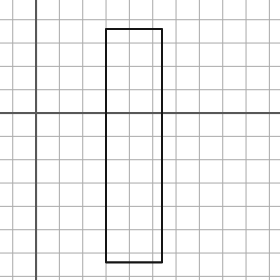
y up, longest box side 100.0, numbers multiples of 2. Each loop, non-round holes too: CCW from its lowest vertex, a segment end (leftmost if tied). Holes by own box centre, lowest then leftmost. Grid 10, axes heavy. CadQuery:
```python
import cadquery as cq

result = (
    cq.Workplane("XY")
    .moveTo(30.0, -64.0)
    .lineTo(54.0, -64.0)
    .lineTo(54.0, 36.0)
    .lineTo(30.0, 36.0)
    .close()
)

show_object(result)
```